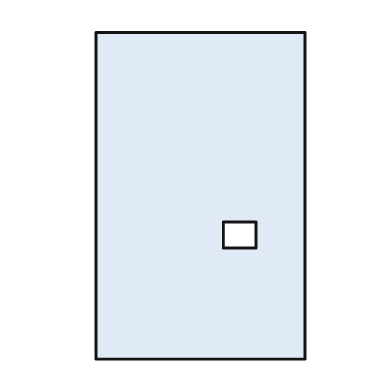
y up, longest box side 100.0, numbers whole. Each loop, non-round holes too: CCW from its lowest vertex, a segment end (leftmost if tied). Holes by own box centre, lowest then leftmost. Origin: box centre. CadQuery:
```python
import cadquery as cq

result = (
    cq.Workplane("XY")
    .moveTo(-32.0, -50.0)
    .lineTo(32.0, -50.0)
    .lineTo(32.0, 50.0)
    .lineTo(-32.0, 50.0)
    .close()
    .moveTo(7.0, -16.0)
    .lineTo(17.0, -16.0)
    .lineTo(17.0, -8.0)
    .lineTo(7.0, -8.0)
    .close()
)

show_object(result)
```